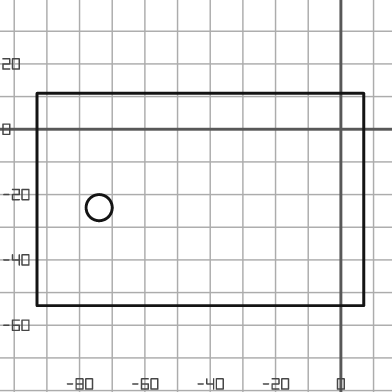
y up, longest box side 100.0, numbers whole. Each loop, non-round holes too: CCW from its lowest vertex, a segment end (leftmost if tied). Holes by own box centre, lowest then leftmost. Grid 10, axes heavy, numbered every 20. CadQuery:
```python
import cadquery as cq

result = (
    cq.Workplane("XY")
    .moveTo(-93.0, -54.0)
    .lineTo(7.0, -54.0)
    .lineTo(7.0, 11.0)
    .lineTo(-93.0, 11.0)
    .close()
    .moveTo(-74.0, -24.0)
    .circle(4.0)
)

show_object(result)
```